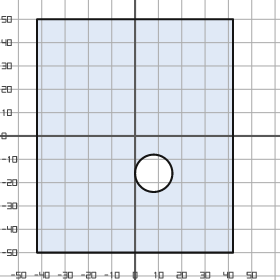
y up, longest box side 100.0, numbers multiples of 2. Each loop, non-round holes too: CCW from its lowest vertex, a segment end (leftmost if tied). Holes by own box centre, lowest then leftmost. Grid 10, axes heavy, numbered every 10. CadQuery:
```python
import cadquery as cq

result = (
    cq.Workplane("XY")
    .moveTo(-42.0, -50.0)
    .lineTo(42.0, -50.0)
    .lineTo(42.0, 50.0)
    .lineTo(-42.0, 50.0)
    .close()
    .moveTo(8.0, -16.0)
    .circle(8.0)
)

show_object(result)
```